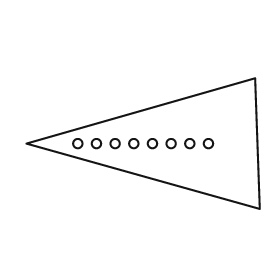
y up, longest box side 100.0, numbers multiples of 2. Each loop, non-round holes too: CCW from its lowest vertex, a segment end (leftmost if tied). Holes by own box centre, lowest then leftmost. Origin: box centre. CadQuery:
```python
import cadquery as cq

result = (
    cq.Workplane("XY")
    .moveTo(50.0, -28.0)
    .lineTo(48.0, 28.0)
    .lineTo(-50.0, 0.0)
    .close()
    .moveTo(-28.0, 0.0)
    .circle(2.0)
    .moveTo(-20.0, 0.0)
    .circle(2.0)
    .moveTo(-12.0, 0.0)
    .circle(2.0)
    .moveTo(-4.0, 0.0)
    .circle(2.0)
    .moveTo(4.0, 0.0)
    .circle(2.0)
    .moveTo(12.0, 0.0)
    .circle(2.0)
    .moveTo(20.0, 0.0)
    .circle(2.0)
    .moveTo(28.0, 0.0)
    .circle(2.0)
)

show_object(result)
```